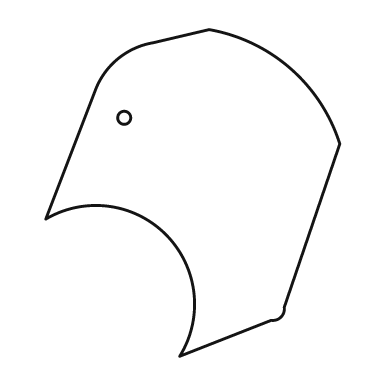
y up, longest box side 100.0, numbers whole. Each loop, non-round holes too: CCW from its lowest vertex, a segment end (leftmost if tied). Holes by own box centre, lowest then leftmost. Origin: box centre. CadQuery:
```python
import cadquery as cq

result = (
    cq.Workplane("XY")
    .moveTo(-4.0, -50.0)
    .lineTo(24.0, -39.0)
    .threePointArc((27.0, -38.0), (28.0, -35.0))
    .lineTo(45.0, 15.0)
    .threePointArc((30.0, 38.0), (5.0, 50.0))
    .lineTo(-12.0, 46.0)
    .threePointArc((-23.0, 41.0), (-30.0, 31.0))
    .lineTo(-45.0, -8.0)
    .threePointArc((-8.0, -13.0), (-4.0, -50.0))
    .close()
    .moveTo(-21.0, 23.0)
    .circle(2.0)
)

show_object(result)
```